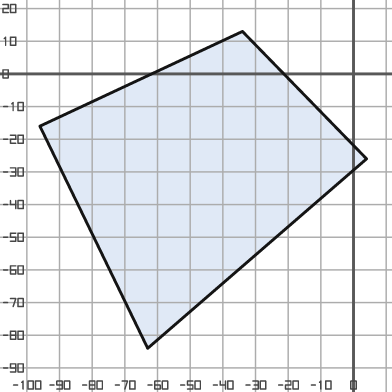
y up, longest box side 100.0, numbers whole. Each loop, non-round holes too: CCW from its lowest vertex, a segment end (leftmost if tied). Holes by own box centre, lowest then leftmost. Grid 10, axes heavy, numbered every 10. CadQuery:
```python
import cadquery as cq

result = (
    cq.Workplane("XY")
    .moveTo(-63.0, -84.0)
    .lineTo(4.0, -26.0)
    .lineTo(-34.0, 13.0)
    .lineTo(-96.0, -16.0)
    .close()
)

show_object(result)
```